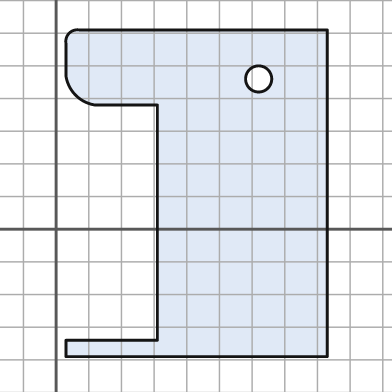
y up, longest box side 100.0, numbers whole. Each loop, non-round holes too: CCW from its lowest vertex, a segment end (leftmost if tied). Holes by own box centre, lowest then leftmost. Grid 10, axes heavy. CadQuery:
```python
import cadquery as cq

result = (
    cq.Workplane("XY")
    .moveTo(3.0, -39.0)
    .lineTo(83.0, -39.0)
    .lineTo(83.0, 61.0)
    .lineTo(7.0, 61.0)
    .threePointArc((4.0, 60.0), (3.0, 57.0))
    .lineTo(3.0, 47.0)
    .threePointArc((6.0, 41.0), (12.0, 38.0))
    .lineTo(31.0, 38.0)
    .lineTo(31.0, -34.0)
    .lineTo(3.0, -34.0)
    .close()
    .moveTo(62.0, 46.0)
    .circle(4.0)
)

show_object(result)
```